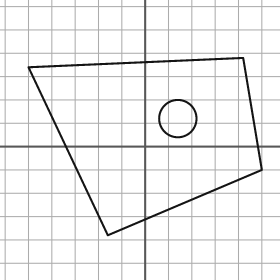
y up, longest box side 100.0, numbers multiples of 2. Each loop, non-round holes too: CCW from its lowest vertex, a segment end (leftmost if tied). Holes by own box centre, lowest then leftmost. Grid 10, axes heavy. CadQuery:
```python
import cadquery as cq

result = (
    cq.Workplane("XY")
    .moveTo(-16.0, -38.0)
    .lineTo(50.0, -10.0)
    .lineTo(42.0, 38.0)
    .lineTo(-50.0, 34.0)
    .close()
    .moveTo(14.0, 12.0)
    .circle(8.0)
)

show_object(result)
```